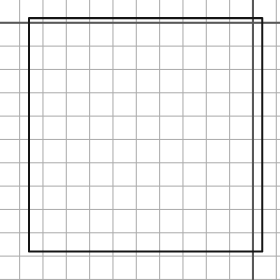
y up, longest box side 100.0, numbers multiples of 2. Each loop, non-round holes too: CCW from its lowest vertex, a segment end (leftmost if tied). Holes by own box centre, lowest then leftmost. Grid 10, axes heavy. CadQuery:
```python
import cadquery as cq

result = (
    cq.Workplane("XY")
    .moveTo(-96.0, -98.0)
    .lineTo(4.0, -98.0)
    .lineTo(4.0, 2.0)
    .lineTo(-96.0, 2.0)
    .close()
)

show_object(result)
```